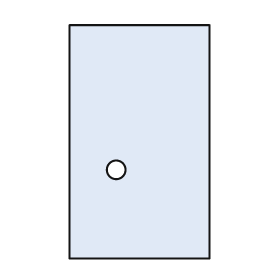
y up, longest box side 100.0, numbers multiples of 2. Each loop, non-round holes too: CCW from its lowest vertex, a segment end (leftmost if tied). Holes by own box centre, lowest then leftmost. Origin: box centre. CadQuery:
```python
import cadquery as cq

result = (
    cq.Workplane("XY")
    .moveTo(-30.0, -50.0)
    .lineTo(30.0, -50.0)
    .lineTo(30.0, 50.0)
    .lineTo(-30.0, 50.0)
    .close()
    .moveTo(-10.0, -12.0)
    .circle(4.0)
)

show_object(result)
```